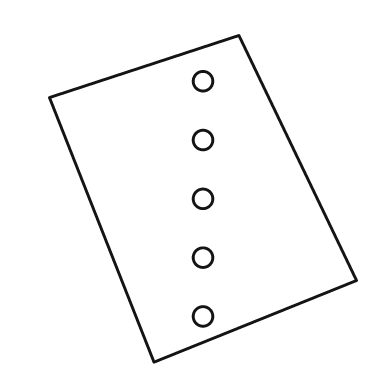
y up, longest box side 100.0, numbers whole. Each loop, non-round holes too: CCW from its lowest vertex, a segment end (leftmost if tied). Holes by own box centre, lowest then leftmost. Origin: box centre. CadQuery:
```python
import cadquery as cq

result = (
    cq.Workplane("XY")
    .moveTo(-15.0, -50.0)
    .lineTo(47.0, -25.0)
    .lineTo(11.0, 50.0)
    .lineTo(-47.0, 31.0)
    .close()
    .moveTo(0.0, -36.0)
    .circle(3.0)
    .moveTo(0.0, -18.0)
    .circle(3.0)
    .moveTo(0.0, 0.0)
    .circle(3.0)
    .moveTo(0.0, 18.0)
    .circle(3.0)
    .moveTo(0.0, 36.0)
    .circle(3.0)
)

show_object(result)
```